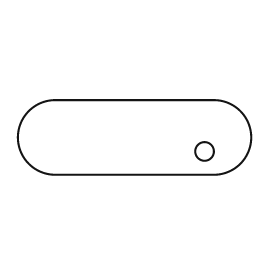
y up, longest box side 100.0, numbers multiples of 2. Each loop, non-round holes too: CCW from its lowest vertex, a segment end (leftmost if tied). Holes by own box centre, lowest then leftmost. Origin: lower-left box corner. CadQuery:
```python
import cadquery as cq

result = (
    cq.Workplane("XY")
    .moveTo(16.0, 0.0)
    .lineTo(84.0, 0.0)
    .threePointArc((100.0, 16.0), (84.0, 32.0))
    .lineTo(16.0, 32.0)
    .threePointArc((0.0, 16.0), (16.0, 0.0))
    .close()
    .moveTo(80.0, 10.0)
    .circle(4.0)
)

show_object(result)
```